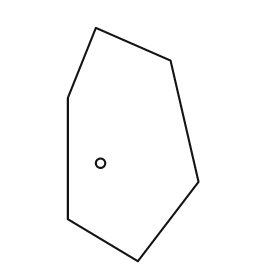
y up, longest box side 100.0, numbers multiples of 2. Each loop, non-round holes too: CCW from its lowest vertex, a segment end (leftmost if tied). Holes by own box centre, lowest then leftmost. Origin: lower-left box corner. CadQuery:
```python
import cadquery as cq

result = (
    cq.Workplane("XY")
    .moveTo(30.0, 0.0)
    .lineTo(56.0, 34.0)
    .lineTo(44.0, 86.0)
    .lineTo(12.0, 100.0)
    .lineTo(0.0, 70.0)
    .lineTo(0.0, 18.0)
    .close()
    .moveTo(14.0, 42.0)
    .circle(2.0)
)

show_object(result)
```